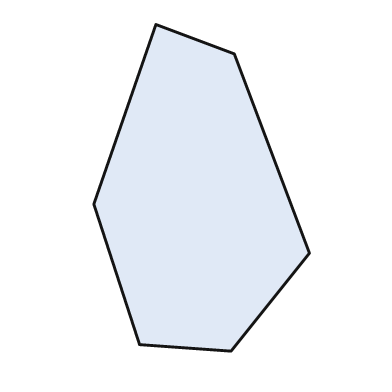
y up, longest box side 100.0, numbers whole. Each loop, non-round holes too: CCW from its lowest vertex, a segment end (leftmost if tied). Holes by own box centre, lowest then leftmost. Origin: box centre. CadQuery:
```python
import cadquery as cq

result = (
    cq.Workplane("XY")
    .moveTo(9.0, -50.0)
    .lineTo(33.0, -20.0)
    .lineTo(10.0, 41.0)
    .lineTo(-14.0, 50.0)
    .lineTo(-33.0, -5.0)
    .lineTo(-19.0, -48.0)
    .close()
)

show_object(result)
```